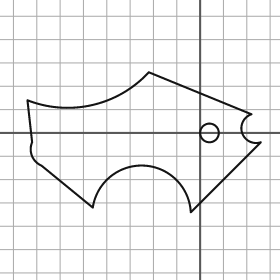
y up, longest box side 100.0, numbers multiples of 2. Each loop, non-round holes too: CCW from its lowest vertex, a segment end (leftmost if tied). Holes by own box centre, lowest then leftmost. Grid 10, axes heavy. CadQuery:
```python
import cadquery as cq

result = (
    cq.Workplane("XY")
    .moveTo(-4.0, -34.0)
    .lineTo(26.0, -4.0)
    .threePointArc((18.0, 0.0), (22.0, 8.0))
    .lineTo(-22.0, 26.0)
    .threePointArc((-46.0, 12.0), (-74.0, 14.0))
    .lineTo(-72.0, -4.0)
    .threePointArc((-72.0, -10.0), (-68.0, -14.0))
    .lineTo(-46.0, -32.0)
    .threePointArc((-24.0, -14.0), (-4.0, -34.0))
    .close()
    .moveTo(4.0, 0.0)
    .circle(4.0)
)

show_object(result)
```